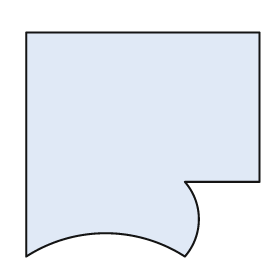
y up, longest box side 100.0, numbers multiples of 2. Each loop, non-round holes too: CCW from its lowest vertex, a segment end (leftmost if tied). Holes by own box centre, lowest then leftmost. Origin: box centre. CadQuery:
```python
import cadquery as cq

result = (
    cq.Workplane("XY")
    .moveTo(-50.0, -48.0)
    .threePointArc((-16.0, -38.0), (18.0, -48.0))
    .threePointArc((24.0, -32.0), (18.0, -16.0))
    .lineTo(50.0, -16.0)
    .lineTo(50.0, 48.0)
    .lineTo(-50.0, 48.0)
    .close()
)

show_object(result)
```